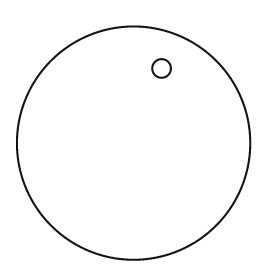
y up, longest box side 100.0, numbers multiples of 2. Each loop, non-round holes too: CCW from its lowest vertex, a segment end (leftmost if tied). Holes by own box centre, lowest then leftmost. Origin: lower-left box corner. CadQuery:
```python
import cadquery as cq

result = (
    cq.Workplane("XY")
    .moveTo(50.0, 50.0)
    .circle(50.0)
    .moveTo(62.0, 82.0)
    .circle(4.0)
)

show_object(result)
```